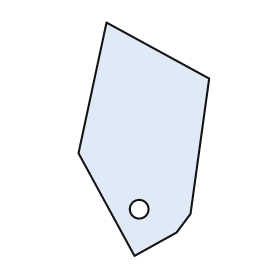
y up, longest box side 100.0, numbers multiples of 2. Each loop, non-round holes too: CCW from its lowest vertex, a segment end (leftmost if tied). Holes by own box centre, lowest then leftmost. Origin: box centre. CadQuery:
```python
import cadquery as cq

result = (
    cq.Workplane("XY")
    .moveTo(-4.0, -50.0)
    .lineTo(14.0, -40.0)
    .lineTo(20.0, -32.0)
    .lineTo(28.0, 26.0)
    .lineTo(-16.0, 50.0)
    .lineTo(-28.0, -6.0)
    .close()
    .moveTo(-2.0, -30.0)
    .circle(4.0)
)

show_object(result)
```